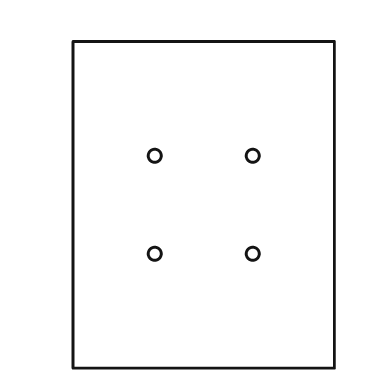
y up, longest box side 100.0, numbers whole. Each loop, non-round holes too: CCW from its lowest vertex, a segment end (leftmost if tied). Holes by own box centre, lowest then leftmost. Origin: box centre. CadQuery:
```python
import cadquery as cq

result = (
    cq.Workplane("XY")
    .moveTo(-40.0, -50.0)
    .lineTo(40.0, -50.0)
    .lineTo(40.0, 50.0)
    .lineTo(-40.0, 50.0)
    .close()
    .moveTo(-15.0, -15.0)
    .circle(2.0)
    .moveTo(15.0, -15.0)
    .circle(2.0)
    .moveTo(-15.0, 15.0)
    .circle(2.0)
    .moveTo(15.0, 15.0)
    .circle(2.0)
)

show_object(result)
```